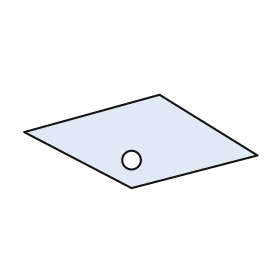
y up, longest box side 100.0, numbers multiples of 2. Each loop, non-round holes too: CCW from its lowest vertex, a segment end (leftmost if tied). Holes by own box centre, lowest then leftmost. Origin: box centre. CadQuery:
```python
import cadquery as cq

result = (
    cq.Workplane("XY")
    .moveTo(-4.0, -20.0)
    .lineTo(50.0, -6.0)
    .lineTo(8.0, 20.0)
    .lineTo(-50.0, 4.0)
    .close()
    .moveTo(-4.0, -8.0)
    .circle(4.0)
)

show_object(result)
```